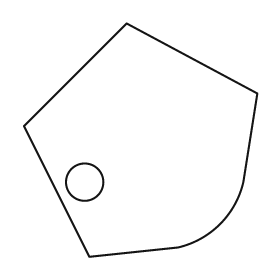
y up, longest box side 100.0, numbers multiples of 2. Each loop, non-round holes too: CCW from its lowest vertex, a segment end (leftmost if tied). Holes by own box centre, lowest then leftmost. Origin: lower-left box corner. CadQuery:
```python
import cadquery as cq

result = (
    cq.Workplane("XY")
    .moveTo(28.0, 0.0)
    .lineTo(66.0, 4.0)
    .threePointArc((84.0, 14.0), (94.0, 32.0))
    .lineTo(100.0, 70.0)
    .lineTo(44.0, 100.0)
    .lineTo(0.0, 56.0)
    .close()
    .moveTo(26.0, 32.0)
    .circle(8.0)
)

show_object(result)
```